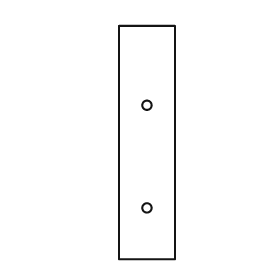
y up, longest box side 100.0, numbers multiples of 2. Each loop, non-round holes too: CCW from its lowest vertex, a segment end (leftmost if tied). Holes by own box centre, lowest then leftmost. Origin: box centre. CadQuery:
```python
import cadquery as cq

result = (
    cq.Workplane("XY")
    .moveTo(-12.0, -50.0)
    .lineTo(12.0, -50.0)
    .lineTo(12.0, 50.0)
    .lineTo(-12.0, 50.0)
    .close()
    .moveTo(0.0, -28.0)
    .circle(2.0)
    .moveTo(0.0, 16.0)
    .circle(2.0)
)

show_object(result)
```